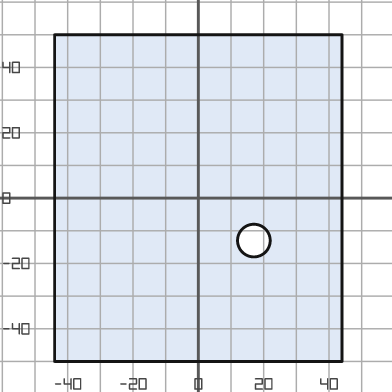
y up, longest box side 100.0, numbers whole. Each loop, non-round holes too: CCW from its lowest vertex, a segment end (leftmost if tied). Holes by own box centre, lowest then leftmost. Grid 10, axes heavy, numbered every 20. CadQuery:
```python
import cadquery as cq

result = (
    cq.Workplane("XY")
    .moveTo(-44.0, -50.0)
    .lineTo(44.0, -50.0)
    .lineTo(44.0, 50.0)
    .lineTo(-44.0, 50.0)
    .close()
    .moveTo(17.0, -13.0)
    .circle(5.0)
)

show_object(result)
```